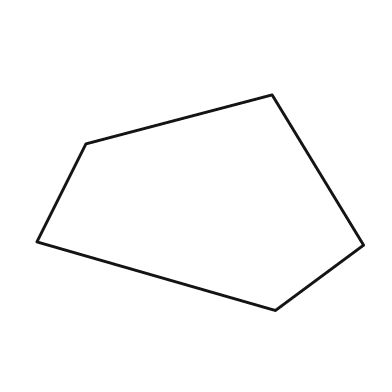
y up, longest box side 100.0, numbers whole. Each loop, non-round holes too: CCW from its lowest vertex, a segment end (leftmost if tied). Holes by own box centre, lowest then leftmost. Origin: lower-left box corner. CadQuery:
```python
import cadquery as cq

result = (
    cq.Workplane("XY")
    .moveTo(73.0, 0.0)
    .lineTo(100.0, 20.0)
    .lineTo(72.0, 66.0)
    .lineTo(15.0, 51.0)
    .lineTo(0.0, 21.0)
    .close()
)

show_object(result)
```